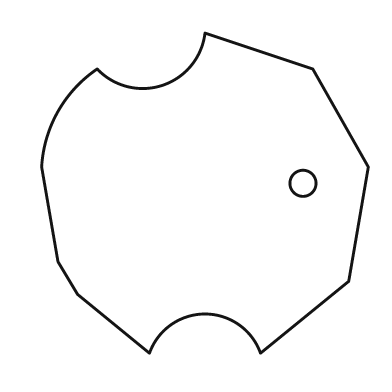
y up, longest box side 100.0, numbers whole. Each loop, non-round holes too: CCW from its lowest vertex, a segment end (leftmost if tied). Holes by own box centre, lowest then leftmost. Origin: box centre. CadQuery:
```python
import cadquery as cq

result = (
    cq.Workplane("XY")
    .moveTo(-17.0, -49.0)
    .threePointArc((0.0, -37.0), (17.0, -49.0))
    .lineTo(44.0, -27.0)
    .lineTo(50.0, 8.0)
    .lineTo(33.0, 38.0)
    .lineTo(0.0, 49.0)
    .threePointArc((-13.0, 33.0), (-33.0, 38.0))
    .threePointArc((-45.0, 25.0), (-50.0, 8.0))
    .lineTo(-45.0, -21.0)
    .lineTo(-39.0, -31.0)
    .close()
    .moveTo(30.0, 3.0)
    .circle(4.0)
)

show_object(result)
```